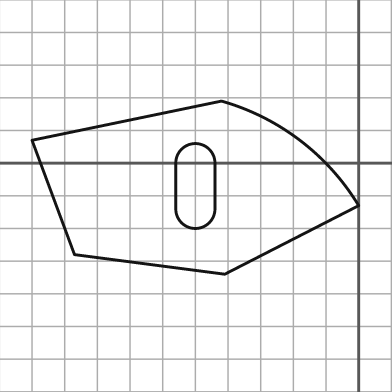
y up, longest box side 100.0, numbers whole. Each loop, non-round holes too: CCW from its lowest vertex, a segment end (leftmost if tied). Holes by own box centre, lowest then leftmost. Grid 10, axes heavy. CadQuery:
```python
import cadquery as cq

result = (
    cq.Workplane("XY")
    .moveTo(-41.0, -34.0)
    .lineTo(0.0, -13.0)
    .threePointArc((-18.0, 7.0), (-42.0, 19.0))
    .lineTo(-100.0, 7.0)
    .lineTo(-87.0, -28.0)
    .close()
    .moveTo(-56.0, -14.0)
    .threePointArc((-50.0, -20.0), (-44.0, -14.0))
    .lineTo(-44.0, 0.0)
    .threePointArc((-50.0, 6.0), (-56.0, 0.0))
    .close()
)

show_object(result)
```